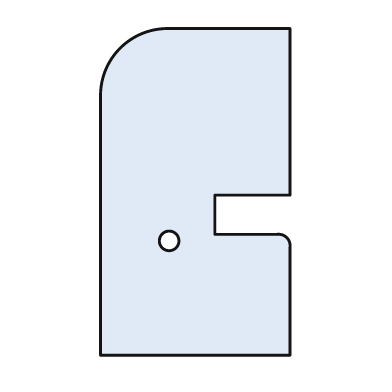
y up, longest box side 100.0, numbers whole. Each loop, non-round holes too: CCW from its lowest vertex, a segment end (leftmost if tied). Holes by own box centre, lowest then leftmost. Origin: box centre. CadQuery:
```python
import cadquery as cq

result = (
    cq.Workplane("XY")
    .moveTo(-29.0, -50.0)
    .lineTo(29.0, -50.0)
    .lineTo(29.0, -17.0)
    .threePointArc((28.0, -14.0), (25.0, -13.0))
    .lineTo(6.0, -13.0)
    .lineTo(6.0, -1.0)
    .lineTo(29.0, -1.0)
    .lineTo(29.0, 50.0)
    .lineTo(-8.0, 50.0)
    .threePointArc((-23.0, 44.0), (-29.0, 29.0))
    .close()
    .moveTo(-8.0, -15.0)
    .circle(3.0)
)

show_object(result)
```